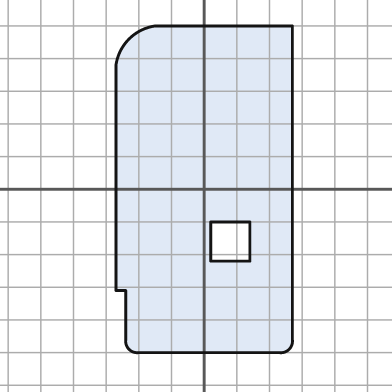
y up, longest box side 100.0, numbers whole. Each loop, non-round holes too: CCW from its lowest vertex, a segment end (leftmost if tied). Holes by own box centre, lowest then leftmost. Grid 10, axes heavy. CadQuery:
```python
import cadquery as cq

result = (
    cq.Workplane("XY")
    .moveTo(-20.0, -50.0)
    .lineTo(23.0, -50.0)
    .threePointArc((26.0, -49.0), (27.0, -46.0))
    .lineTo(27.0, 50.0)
    .lineTo(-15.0, 50.0)
    .threePointArc((-23.0, 46.0), (-27.0, 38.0))
    .lineTo(-27.0, -31.0)
    .lineTo(-24.0, -31.0)
    .lineTo(-24.0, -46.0)
    .threePointArc((-23.0, -49.0), (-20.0, -50.0))
    .close()
    .moveTo(2.0, -22.0)
    .lineTo(14.0, -22.0)
    .lineTo(14.0, -10.0)
    .lineTo(2.0, -10.0)
    .close()
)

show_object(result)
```